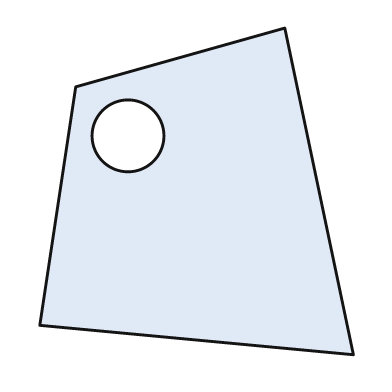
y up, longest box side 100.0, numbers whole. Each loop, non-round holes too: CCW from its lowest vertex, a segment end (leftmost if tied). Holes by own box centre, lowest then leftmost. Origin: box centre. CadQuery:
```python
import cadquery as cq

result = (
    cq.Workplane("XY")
    .moveTo(48.0, -50.0)
    .lineTo(27.0, 50.0)
    .lineTo(-37.0, 32.0)
    .lineTo(-48.0, -41.0)
    .close()
    .moveTo(-21.0, 17.0)
    .circle(11.0)
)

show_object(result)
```